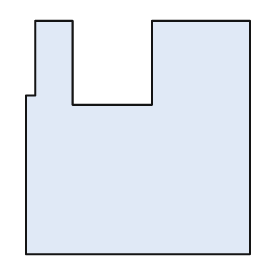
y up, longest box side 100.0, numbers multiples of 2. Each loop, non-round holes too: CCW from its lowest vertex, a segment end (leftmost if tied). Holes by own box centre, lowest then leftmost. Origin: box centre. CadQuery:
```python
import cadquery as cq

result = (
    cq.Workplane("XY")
    .moveTo(-48.0, -50.0)
    .lineTo(48.0, -50.0)
    .lineTo(48.0, 50.0)
    .lineTo(6.0, 50.0)
    .lineTo(6.0, 14.0)
    .lineTo(-28.0, 14.0)
    .lineTo(-28.0, 50.0)
    .lineTo(-44.0, 50.0)
    .lineTo(-44.0, 18.0)
    .lineTo(-48.0, 18.0)
    .close()
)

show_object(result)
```